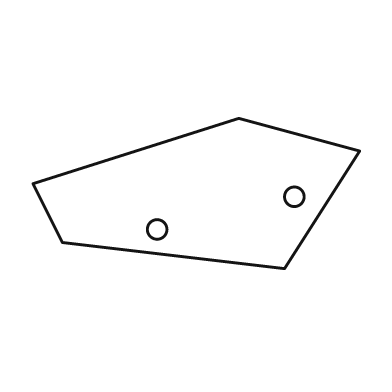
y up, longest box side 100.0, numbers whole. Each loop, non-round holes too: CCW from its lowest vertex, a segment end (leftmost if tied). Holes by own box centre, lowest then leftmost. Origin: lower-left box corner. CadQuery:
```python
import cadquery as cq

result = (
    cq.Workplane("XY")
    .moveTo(77.0, 0.0)
    .lineTo(100.0, 36.0)
    .lineTo(63.0, 46.0)
    .lineTo(0.0, 26.0)
    .lineTo(9.0, 8.0)
    .close()
    .moveTo(38.0, 12.0)
    .circle(3.0)
    .moveTo(80.0, 22.0)
    .circle(3.0)
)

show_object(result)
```